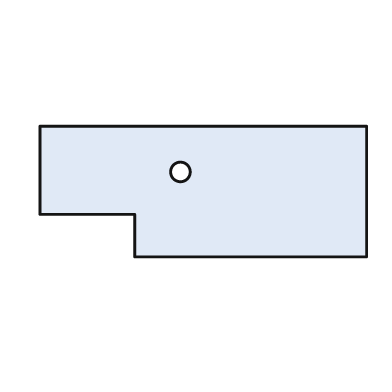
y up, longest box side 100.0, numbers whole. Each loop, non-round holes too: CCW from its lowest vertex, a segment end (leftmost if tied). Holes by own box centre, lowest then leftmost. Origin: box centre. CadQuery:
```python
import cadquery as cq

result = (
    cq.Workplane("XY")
    .moveTo(-21.0, -20.0)
    .lineTo(50.0, -20.0)
    .lineTo(50.0, 20.0)
    .lineTo(-50.0, 20.0)
    .lineTo(-50.0, -7.0)
    .lineTo(-21.0, -7.0)
    .close()
    .moveTo(-7.0, 6.0)
    .circle(3.0)
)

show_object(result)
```